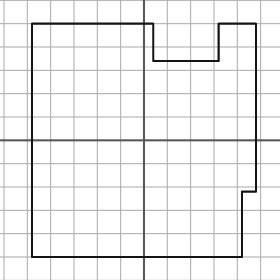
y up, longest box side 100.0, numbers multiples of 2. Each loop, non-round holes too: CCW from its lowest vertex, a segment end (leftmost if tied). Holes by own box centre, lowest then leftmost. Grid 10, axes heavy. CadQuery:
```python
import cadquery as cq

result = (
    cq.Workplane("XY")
    .moveTo(-48.0, -50.0)
    .lineTo(42.0, -50.0)
    .lineTo(42.0, -22.0)
    .lineTo(48.0, -22.0)
    .lineTo(48.0, 50.0)
    .lineTo(32.0, 50.0)
    .lineTo(32.0, 34.0)
    .lineTo(4.0, 34.0)
    .lineTo(4.0, 50.0)
    .lineTo(-48.0, 50.0)
    .close()
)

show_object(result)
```